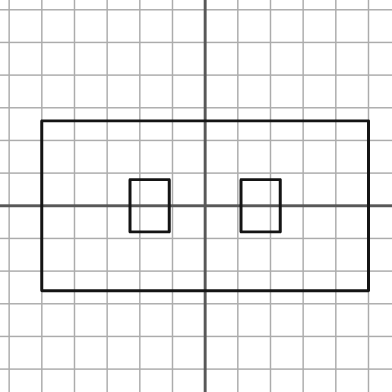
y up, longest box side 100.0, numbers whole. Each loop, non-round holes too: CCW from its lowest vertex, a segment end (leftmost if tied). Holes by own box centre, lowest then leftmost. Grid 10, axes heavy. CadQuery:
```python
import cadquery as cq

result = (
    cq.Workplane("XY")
    .moveTo(-50.0, -26.0)
    .lineTo(50.0, -26.0)
    .lineTo(50.0, 26.0)
    .lineTo(-50.0, 26.0)
    .close()
    .moveTo(-23.0, -8.0)
    .lineTo(-11.0, -8.0)
    .lineTo(-11.0, 8.0)
    .lineTo(-23.0, 8.0)
    .close()
    .moveTo(11.0, -8.0)
    .lineTo(23.0, -8.0)
    .lineTo(23.0, 8.0)
    .lineTo(11.0, 8.0)
    .close()
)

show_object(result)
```